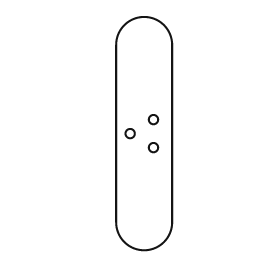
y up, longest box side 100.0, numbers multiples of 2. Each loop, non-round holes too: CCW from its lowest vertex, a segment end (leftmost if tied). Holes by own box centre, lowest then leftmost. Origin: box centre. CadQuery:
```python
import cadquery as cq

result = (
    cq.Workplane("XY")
    .moveTo(-12.0, -38.0)
    .threePointArc((0.0, -50.0), (12.0, -38.0))
    .lineTo(12.0, 38.0)
    .threePointArc((0.0, 50.0), (-12.0, 38.0))
    .close()
    .moveTo(4.0, -6.0)
    .circle(2.0)
    .moveTo(-6.0, 0.0)
    .circle(2.0)
    .moveTo(4.0, 6.0)
    .circle(2.0)
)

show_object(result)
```